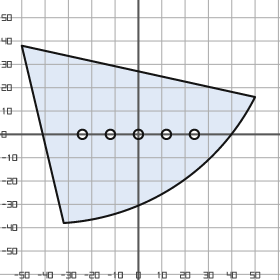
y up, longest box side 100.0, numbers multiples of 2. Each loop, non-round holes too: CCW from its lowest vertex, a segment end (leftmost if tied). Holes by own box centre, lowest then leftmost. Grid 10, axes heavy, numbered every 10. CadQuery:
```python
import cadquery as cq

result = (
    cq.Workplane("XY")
    .moveTo(-32.0, -38.0)
    .threePointArc((16.0, -22.0), (50.0, 16.0))
    .lineTo(-50.0, 38.0)
    .close()
    .moveTo(-24.0, 0.0)
    .circle(2.0)
    .moveTo(-12.0, 0.0)
    .circle(2.0)
    .moveTo(0.0, 0.0)
    .circle(2.0)
    .moveTo(12.0, 0.0)
    .circle(2.0)
    .moveTo(24.0, 0.0)
    .circle(2.0)
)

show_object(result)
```